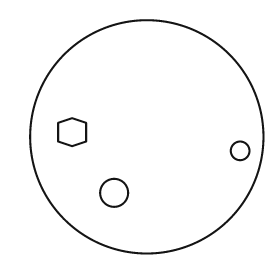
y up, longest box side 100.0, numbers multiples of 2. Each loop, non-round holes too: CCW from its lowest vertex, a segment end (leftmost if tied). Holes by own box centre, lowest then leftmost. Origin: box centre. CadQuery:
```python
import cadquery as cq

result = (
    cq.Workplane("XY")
    .moveTo(0.0, 0.0)
    .circle(50.0)
    .moveTo(-14.0, -24.0)
    .circle(6.0)
    .moveTo(40.0, -6.0)
    .circle(4.0)
    .moveTo(-32.0, -4.0)
    .lineTo(-26.0, -2.0)
    .lineTo(-26.0, 6.0)
    .lineTo(-32.0, 8.0)
    .lineTo(-38.0, 6.0)
    .lineTo(-38.0, -2.0)
    .close()
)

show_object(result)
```